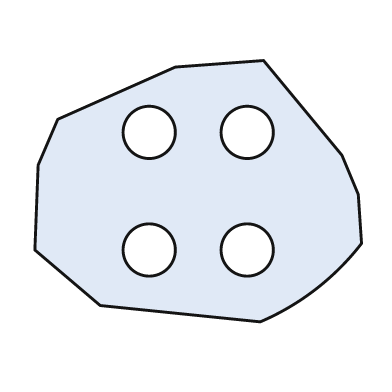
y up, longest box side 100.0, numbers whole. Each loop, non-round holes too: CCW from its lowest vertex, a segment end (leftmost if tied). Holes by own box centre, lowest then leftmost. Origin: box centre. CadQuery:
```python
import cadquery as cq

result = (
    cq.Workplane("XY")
    .moveTo(19.0, -40.0)
    .threePointArc((36.0, -30.0), (50.0, -16.0))
    .lineTo(49.0, -1.0)
    .lineTo(44.0, 11.0)
    .lineTo(20.0, 40.0)
    .lineTo(-7.0, 38.0)
    .lineTo(-43.0, 22.0)
    .lineTo(-49.0, 8.0)
    .lineTo(-50.0, -18.0)
    .lineTo(-30.0, -35.0)
    .close()
    .moveTo(-15.0, -18.0)
    .circle(8.0)
    .moveTo(15.0, -18.0)
    .circle(8.0)
    .moveTo(-15.0, 18.0)
    .circle(8.0)
    .moveTo(15.0, 18.0)
    .circle(8.0)
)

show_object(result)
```